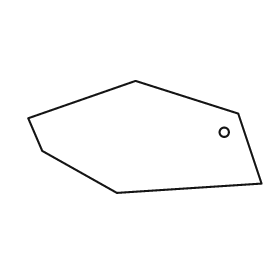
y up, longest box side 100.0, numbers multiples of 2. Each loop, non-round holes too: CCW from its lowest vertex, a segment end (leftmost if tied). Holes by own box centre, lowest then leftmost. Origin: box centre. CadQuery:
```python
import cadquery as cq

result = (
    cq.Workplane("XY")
    .moveTo(-12.0, -24.0)
    .lineTo(50.0, -20.0)
    .lineTo(40.0, 10.0)
    .lineTo(-4.0, 24.0)
    .lineTo(-50.0, 8.0)
    .lineTo(-44.0, -6.0)
    .close()
    .moveTo(34.0, 2.0)
    .circle(2.0)
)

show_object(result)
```